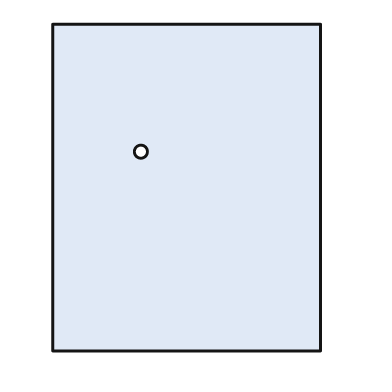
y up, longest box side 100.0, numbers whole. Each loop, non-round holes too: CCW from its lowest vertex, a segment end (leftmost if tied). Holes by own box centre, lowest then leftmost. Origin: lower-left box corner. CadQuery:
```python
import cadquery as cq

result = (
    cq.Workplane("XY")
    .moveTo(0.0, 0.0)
    .lineTo(82.0, 0.0)
    .lineTo(82.0, 100.0)
    .lineTo(0.0, 100.0)
    .close()
    .moveTo(27.0, 61.0)
    .circle(2.0)
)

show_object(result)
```